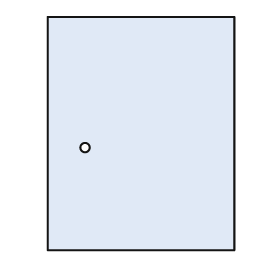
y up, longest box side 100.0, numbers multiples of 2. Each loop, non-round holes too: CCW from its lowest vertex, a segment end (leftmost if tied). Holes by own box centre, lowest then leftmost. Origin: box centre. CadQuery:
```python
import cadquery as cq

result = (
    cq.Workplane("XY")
    .moveTo(-40.0, -50.0)
    .lineTo(40.0, -50.0)
    .lineTo(40.0, 50.0)
    .lineTo(-40.0, 50.0)
    .close()
    .moveTo(-24.0, -6.0)
    .circle(2.0)
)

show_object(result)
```